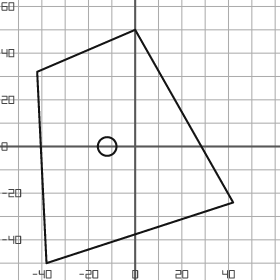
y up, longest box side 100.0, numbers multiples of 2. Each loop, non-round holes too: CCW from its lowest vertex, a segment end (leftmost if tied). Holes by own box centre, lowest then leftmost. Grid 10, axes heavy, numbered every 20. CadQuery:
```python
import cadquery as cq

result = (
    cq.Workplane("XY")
    .moveTo(-38.0, -50.0)
    .lineTo(42.0, -24.0)
    .lineTo(0.0, 50.0)
    .lineTo(-42.0, 32.0)
    .close()
    .moveTo(-12.0, 0.0)
    .circle(4.0)
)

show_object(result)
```